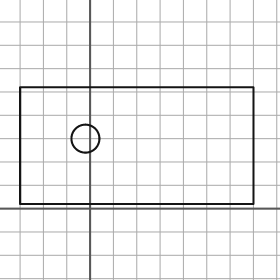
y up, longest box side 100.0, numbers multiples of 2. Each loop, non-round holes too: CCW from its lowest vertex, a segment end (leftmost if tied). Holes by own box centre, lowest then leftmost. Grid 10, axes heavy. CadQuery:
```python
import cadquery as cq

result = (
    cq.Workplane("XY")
    .moveTo(-30.0, 2.0)
    .lineTo(70.0, 2.0)
    .lineTo(70.0, 52.0)
    .lineTo(-30.0, 52.0)
    .close()
    .moveTo(-2.0, 30.0)
    .circle(6.0)
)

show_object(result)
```